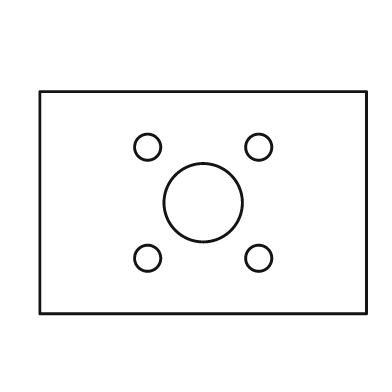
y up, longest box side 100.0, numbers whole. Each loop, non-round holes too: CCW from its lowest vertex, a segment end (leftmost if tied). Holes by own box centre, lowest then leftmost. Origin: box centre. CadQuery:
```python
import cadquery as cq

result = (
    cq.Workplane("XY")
    .moveTo(-50.0, -34.0)
    .lineTo(50.0, -34.0)
    .lineTo(50.0, 34.0)
    .lineTo(-50.0, 34.0)
    .close()
    .moveTo(-17.0, -17.0)
    .circle(4.0)
    .moveTo(17.0, -17.0)
    .circle(4.0)
    .moveTo(0.0, 0.0)
    .circle(12.0)
    .moveTo(-17.0, 17.0)
    .circle(4.0)
    .moveTo(17.0, 17.0)
    .circle(4.0)
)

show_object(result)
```